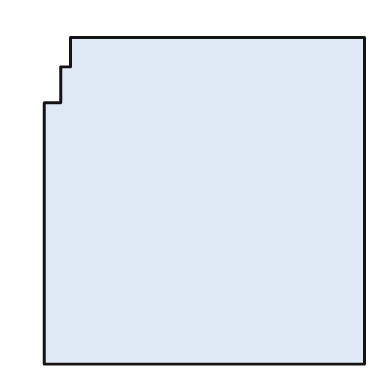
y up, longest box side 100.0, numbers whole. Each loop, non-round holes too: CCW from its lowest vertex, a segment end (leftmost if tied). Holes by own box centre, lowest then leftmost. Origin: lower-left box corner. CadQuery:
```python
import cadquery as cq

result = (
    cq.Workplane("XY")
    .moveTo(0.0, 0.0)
    .lineTo(98.0, 0.0)
    .lineTo(98.0, 100.0)
    .lineTo(8.0, 100.0)
    .lineTo(8.0, 91.0)
    .lineTo(5.0, 91.0)
    .lineTo(5.0, 80.0)
    .lineTo(0.0, 80.0)
    .close()
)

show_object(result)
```